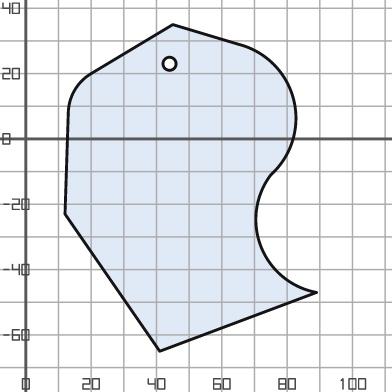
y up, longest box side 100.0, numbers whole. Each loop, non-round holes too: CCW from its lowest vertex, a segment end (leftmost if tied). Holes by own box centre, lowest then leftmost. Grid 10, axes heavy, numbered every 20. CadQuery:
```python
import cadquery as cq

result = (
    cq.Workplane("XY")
    .moveTo(41.0, -65.0)
    .lineTo(89.0, -47.0)
    .threePointArc((72.0, -33.0), (75.0, -11.0))
    .threePointArc((82.0, 12.0), (65.0, 29.0))
    .lineTo(45.0, 35.0)
    .lineTo(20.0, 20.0)
    .threePointArc((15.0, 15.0), (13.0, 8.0))
    .lineTo(12.0, -23.0)
    .close()
    .moveTo(44.0, 23.0)
    .circle(2.0)
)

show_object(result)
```